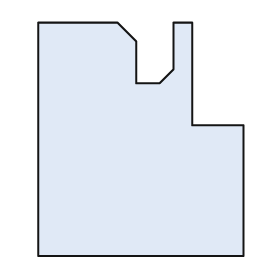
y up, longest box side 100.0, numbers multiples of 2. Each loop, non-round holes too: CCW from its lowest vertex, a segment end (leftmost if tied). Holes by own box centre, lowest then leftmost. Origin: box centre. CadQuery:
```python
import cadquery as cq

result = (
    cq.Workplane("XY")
    .moveTo(-44.0, -50.0)
    .lineTo(44.0, -50.0)
    .lineTo(44.0, 6.0)
    .lineTo(22.0, 6.0)
    .lineTo(22.0, 50.0)
    .lineTo(14.0, 50.0)
    .lineTo(14.0, 30.0)
    .lineTo(8.0, 24.0)
    .lineTo(-2.0, 24.0)
    .lineTo(-2.0, 42.0)
    .lineTo(-10.0, 50.0)
    .lineTo(-44.0, 50.0)
    .close()
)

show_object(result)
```